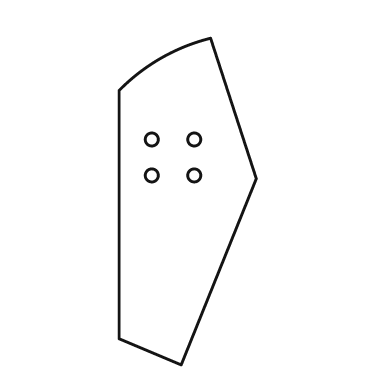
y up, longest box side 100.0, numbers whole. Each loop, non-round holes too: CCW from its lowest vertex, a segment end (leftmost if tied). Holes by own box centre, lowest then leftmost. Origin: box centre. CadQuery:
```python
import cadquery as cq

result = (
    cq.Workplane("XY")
    .moveTo(-2.0, -50.0)
    .lineTo(21.0, 7.0)
    .lineTo(7.0, 50.0)
    .threePointArc((-8.0, 44.0), (-21.0, 34.0))
    .lineTo(-21.0, -42.0)
    .close()
    .moveTo(-11.0, 8.0)
    .circle(2.0)
    .moveTo(2.0, 8.0)
    .circle(2.0)
    .moveTo(-11.0, 19.0)
    .circle(2.0)
    .moveTo(2.0, 19.0)
    .circle(2.0)
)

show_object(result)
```